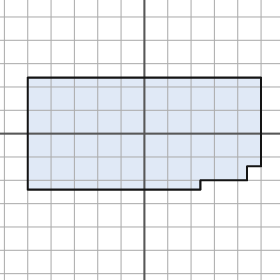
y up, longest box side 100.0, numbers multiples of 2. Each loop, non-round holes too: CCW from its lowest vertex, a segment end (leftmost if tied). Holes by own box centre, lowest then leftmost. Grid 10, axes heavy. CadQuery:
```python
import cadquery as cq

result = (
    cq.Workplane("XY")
    .moveTo(-50.0, -24.0)
    .lineTo(24.0, -24.0)
    .lineTo(24.0, -20.0)
    .lineTo(44.0, -20.0)
    .lineTo(44.0, -14.0)
    .lineTo(50.0, -14.0)
    .lineTo(50.0, 24.0)
    .lineTo(-50.0, 24.0)
    .close()
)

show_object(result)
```